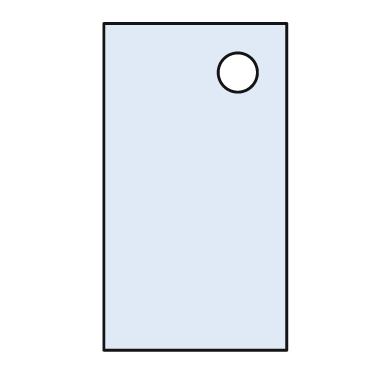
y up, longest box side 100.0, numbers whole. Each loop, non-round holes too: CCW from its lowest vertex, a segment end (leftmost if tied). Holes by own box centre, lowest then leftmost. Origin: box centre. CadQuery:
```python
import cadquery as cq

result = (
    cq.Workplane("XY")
    .moveTo(-28.0, -50.0)
    .lineTo(28.0, -50.0)
    .lineTo(28.0, 50.0)
    .lineTo(-28.0, 50.0)
    .close()
    .moveTo(13.0, 35.0)
    .circle(6.0)
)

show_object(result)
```